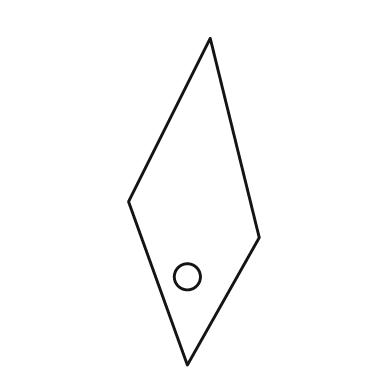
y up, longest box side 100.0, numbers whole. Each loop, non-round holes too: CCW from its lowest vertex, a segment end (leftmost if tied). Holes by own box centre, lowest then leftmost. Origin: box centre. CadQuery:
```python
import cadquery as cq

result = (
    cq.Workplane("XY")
    .moveTo(-2.0, -50.0)
    .lineTo(20.0, -11.0)
    .lineTo(5.0, 50.0)
    .lineTo(-20.0, 0.0)
    .close()
    .moveTo(-2.0, -23.0)
    .circle(4.0)
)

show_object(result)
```